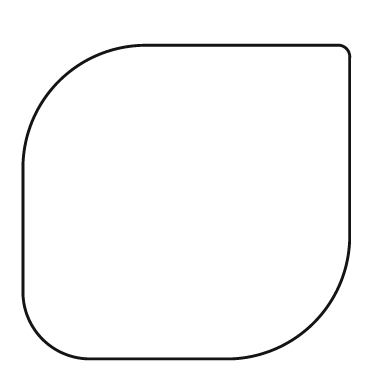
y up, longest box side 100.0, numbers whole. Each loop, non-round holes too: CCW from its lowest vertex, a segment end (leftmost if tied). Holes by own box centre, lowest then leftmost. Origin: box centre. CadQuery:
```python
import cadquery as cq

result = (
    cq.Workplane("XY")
    .moveTo(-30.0, -48.0)
    .lineTo(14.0, -48.0)
    .threePointArc((39.0, -37.0), (50.0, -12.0))
    .lineTo(50.0, 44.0)
    .threePointArc((49.0, 47.0), (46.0, 48.0))
    .lineTo(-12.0, 48.0)
    .threePointArc((-39.0, 37.0), (-50.0, 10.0))
    .lineTo(-50.0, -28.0)
    .threePointArc((-44.0, -42.0), (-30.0, -48.0))
    .close()
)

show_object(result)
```